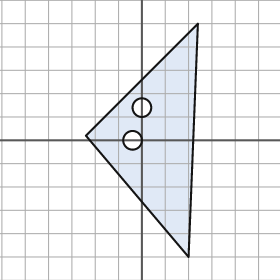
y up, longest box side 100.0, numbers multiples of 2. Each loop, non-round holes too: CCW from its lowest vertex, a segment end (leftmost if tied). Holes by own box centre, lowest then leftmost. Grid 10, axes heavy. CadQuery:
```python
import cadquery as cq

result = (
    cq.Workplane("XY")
    .moveTo(20.0, -50.0)
    .lineTo(24.0, 50.0)
    .lineTo(-24.0, 2.0)
    .close()
    .moveTo(-4.0, 0.0)
    .circle(4.0)
    .moveTo(0.0, 14.0)
    .circle(4.0)
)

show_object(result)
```